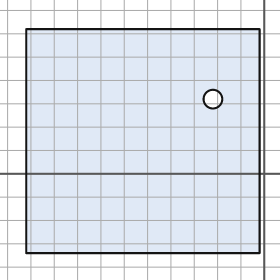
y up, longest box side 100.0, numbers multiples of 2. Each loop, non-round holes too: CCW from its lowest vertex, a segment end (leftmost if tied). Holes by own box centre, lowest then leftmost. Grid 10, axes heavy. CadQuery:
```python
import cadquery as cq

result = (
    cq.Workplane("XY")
    .moveTo(-102.0, -34.0)
    .lineTo(-2.0, -34.0)
    .lineTo(-2.0, 62.0)
    .lineTo(-102.0, 62.0)
    .close()
    .moveTo(-22.0, 32.0)
    .circle(4.0)
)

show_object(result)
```